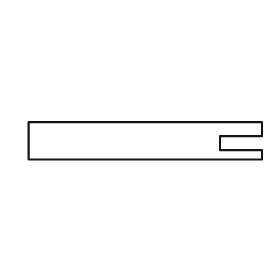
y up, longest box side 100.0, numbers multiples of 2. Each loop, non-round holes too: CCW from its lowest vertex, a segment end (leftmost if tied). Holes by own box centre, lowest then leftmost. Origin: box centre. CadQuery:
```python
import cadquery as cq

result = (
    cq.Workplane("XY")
    .moveTo(-50.0, -8.0)
    .lineTo(50.0, -8.0)
    .lineTo(50.0, -4.0)
    .lineTo(32.0, -4.0)
    .lineTo(32.0, 2.0)
    .lineTo(50.0, 2.0)
    .lineTo(50.0, 8.0)
    .lineTo(-50.0, 8.0)
    .close()
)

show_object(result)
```